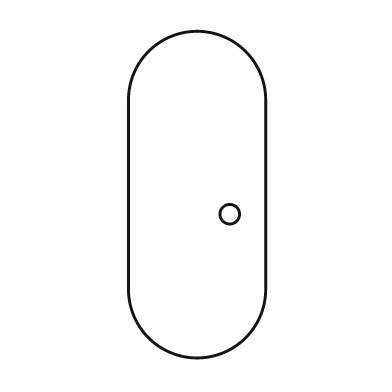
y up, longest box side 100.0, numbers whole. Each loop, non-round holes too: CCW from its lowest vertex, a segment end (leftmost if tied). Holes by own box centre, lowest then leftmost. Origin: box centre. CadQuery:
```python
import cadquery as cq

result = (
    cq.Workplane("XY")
    .moveTo(-21.0, -29.0)
    .threePointArc((0.0, -50.0), (21.0, -29.0))
    .lineTo(21.0, 29.0)
    .threePointArc((0.0, 50.0), (-21.0, 29.0))
    .close()
    .moveTo(10.0, -6.0)
    .circle(3.0)
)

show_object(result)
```